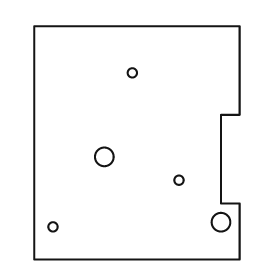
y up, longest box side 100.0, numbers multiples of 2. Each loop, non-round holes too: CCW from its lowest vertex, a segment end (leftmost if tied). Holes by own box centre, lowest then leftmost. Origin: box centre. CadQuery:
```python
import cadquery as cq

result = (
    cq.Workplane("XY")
    .moveTo(-44.0, -50.0)
    .lineTo(44.0, -50.0)
    .lineTo(44.0, -26.0)
    .lineTo(36.0, -26.0)
    .lineTo(36.0, 12.0)
    .lineTo(44.0, 12.0)
    .lineTo(44.0, 50.0)
    .lineTo(-44.0, 50.0)
    .close()
    .moveTo(-36.0, -36.0)
    .circle(2.0)
    .moveTo(36.0, -34.0)
    .circle(4.0)
    .moveTo(18.0, -16.0)
    .circle(2.0)
    .moveTo(-14.0, -6.0)
    .circle(4.0)
    .moveTo(-2.0, 30.0)
    .circle(2.0)
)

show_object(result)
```